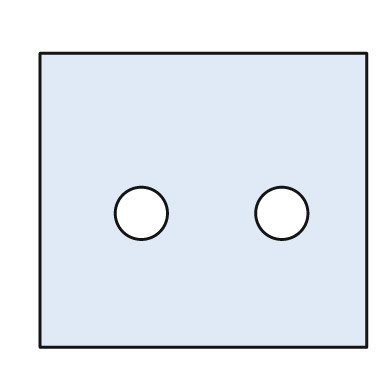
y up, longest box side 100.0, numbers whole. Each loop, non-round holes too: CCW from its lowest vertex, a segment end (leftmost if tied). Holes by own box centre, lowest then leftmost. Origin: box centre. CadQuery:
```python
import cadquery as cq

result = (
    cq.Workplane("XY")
    .moveTo(-50.0, -45.0)
    .lineTo(50.0, -45.0)
    .lineTo(50.0, 45.0)
    .lineTo(-50.0, 45.0)
    .close()
    .moveTo(-19.0, -4.0)
    .circle(8.0)
    .moveTo(24.0, -4.0)
    .circle(8.0)
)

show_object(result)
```